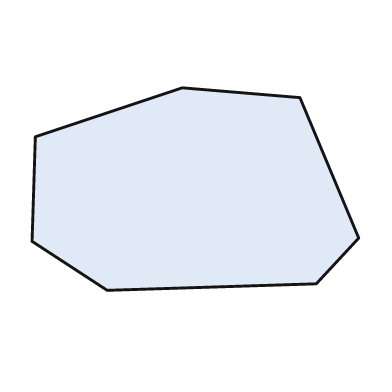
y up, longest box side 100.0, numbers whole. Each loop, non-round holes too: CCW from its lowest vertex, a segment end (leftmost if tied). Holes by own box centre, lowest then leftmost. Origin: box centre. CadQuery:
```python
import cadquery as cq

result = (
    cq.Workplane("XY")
    .moveTo(-27.0, -31.0)
    .lineTo(37.0, -29.0)
    .lineTo(50.0, -15.0)
    .lineTo(32.0, 28.0)
    .lineTo(-4.0, 31.0)
    .lineTo(-49.0, 16.0)
    .lineTo(-50.0, -16.0)
    .close()
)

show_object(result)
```